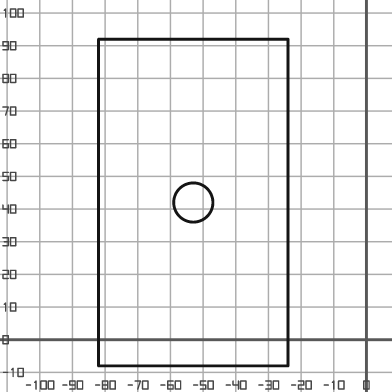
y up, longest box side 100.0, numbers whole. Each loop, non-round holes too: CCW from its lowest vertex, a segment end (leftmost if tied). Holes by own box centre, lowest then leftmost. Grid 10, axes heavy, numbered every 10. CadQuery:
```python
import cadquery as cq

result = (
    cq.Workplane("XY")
    .moveTo(-82.0, -8.0)
    .lineTo(-24.0, -8.0)
    .lineTo(-24.0, 92.0)
    .lineTo(-82.0, 92.0)
    .close()
    .moveTo(-53.0, 42.0)
    .circle(6.0)
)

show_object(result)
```